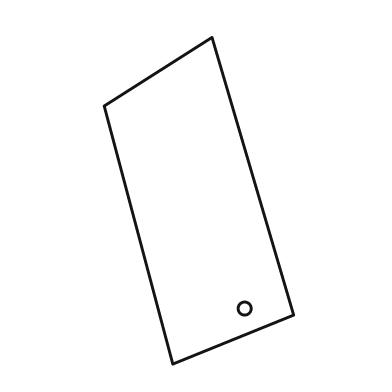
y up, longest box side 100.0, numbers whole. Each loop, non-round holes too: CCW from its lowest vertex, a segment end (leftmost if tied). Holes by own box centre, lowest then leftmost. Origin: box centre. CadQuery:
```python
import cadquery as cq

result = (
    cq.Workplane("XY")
    .moveTo(-8.0, -50.0)
    .lineTo(29.0, -35.0)
    .lineTo(4.0, 50.0)
    .lineTo(-29.0, 29.0)
    .close()
    .moveTo(14.0, -33.0)
    .circle(2.0)
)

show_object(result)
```